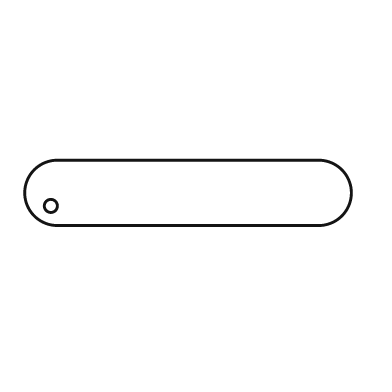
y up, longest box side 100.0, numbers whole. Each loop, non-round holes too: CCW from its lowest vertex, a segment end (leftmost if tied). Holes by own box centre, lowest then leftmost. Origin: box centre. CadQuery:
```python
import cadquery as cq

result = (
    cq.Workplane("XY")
    .moveTo(-40.0, -10.0)
    .lineTo(40.0, -10.0)
    .threePointArc((50.0, 0.0), (40.0, 10.0))
    .lineTo(-40.0, 10.0)
    .threePointArc((-50.0, 0.0), (-40.0, -10.0))
    .close()
    .moveTo(-42.0, -4.0)
    .circle(2.0)
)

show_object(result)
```